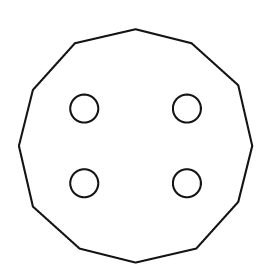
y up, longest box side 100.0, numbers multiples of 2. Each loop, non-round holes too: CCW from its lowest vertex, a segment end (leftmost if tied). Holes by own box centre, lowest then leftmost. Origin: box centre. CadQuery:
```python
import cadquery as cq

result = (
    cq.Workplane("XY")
    .moveTo(0.0, -50.0)
    .lineTo(26.0, -44.0)
    .lineTo(44.0, -24.0)
    .lineTo(50.0, 0.0)
    .lineTo(44.0, 26.0)
    .lineTo(24.0, 44.0)
    .lineTo(0.0, 50.0)
    .lineTo(-26.0, 44.0)
    .lineTo(-44.0, 24.0)
    .lineTo(-50.0, 0.0)
    .lineTo(-44.0, -26.0)
    .lineTo(-24.0, -44.0)
    .close()
    .moveTo(-22.0, -16.0)
    .circle(6.0)
    .moveTo(22.0, -16.0)
    .circle(6.0)
    .moveTo(-22.0, 16.0)
    .circle(6.0)
    .moveTo(22.0, 16.0)
    .circle(6.0)
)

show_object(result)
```